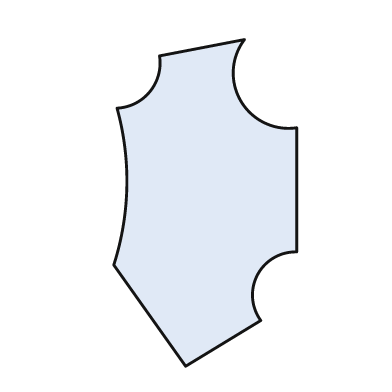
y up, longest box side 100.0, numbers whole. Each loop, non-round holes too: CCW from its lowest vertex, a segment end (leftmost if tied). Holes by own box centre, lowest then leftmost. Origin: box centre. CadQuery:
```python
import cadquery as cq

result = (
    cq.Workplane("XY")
    .moveTo(-6.0, -50.0)
    .lineTo(17.0, -36.0)
    .threePointArc((16.0, -22.0), (28.0, -15.0))
    .lineTo(28.0, 23.0)
    .threePointArc((11.0, 31.0), (12.0, 50.0))
    .lineTo(-14.0, 45.0)
    .threePointArc((-17.0, 34.0), (-27.0, 29.0))
    .threePointArc((-24.0, 5.0), (-28.0, -19.0))
    .close()
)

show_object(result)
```